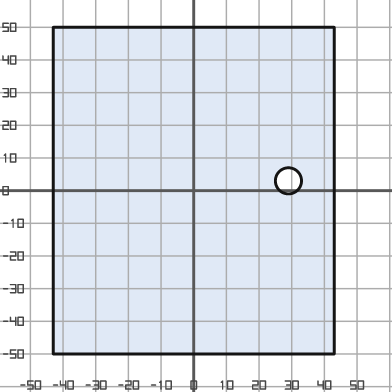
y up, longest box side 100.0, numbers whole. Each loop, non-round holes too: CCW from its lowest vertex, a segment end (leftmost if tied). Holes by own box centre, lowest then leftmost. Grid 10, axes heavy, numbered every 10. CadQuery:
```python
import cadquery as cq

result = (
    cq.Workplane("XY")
    .moveTo(-43.0, -50.0)
    .lineTo(43.0, -50.0)
    .lineTo(43.0, 50.0)
    .lineTo(-43.0, 50.0)
    .close()
    .moveTo(29.0, 3.0)
    .circle(4.0)
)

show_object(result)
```